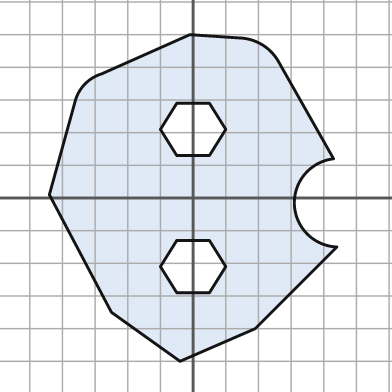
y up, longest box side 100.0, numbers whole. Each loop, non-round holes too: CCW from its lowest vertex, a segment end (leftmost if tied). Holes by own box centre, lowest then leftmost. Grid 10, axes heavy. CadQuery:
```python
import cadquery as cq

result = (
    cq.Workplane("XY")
    .moveTo(-4.0, -50.0)
    .lineTo(19.0, -40.0)
    .lineTo(44.0, -15.0)
    .threePointArc((31.0, -2.0), (43.0, 12.0))
    .lineTo(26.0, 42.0)
    .threePointArc((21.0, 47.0), (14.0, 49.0))
    .lineTo(-1.0, 50.0)
    .lineTo(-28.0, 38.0)
    .threePointArc((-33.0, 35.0), (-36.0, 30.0))
    .lineTo(-44.0, 1.0)
    .lineTo(-25.0, -35.0)
    .close()
    .moveTo(-5.0, -29.0)
    .lineTo(5.0, -29.0)
    .lineTo(10.0, -21.0)
    .lineTo(5.0, -13.0)
    .lineTo(-5.0, -13.0)
    .lineTo(-10.0, -21.0)
    .close()
    .moveTo(-5.0, 13.0)
    .lineTo(5.0, 13.0)
    .lineTo(10.0, 21.0)
    .lineTo(5.0, 29.0)
    .lineTo(-5.0, 29.0)
    .lineTo(-10.0, 21.0)
    .close()
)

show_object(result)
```